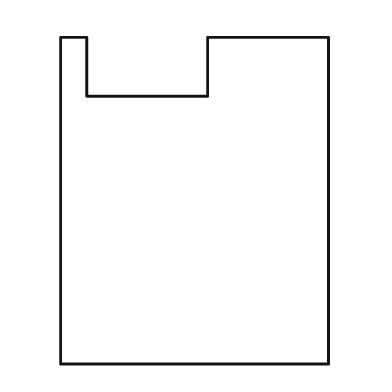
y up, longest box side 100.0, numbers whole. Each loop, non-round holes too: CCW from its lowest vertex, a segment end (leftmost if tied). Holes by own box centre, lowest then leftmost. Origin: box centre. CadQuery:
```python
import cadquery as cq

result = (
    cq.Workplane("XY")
    .moveTo(-41.0, -50.0)
    .lineTo(41.0, -50.0)
    .lineTo(41.0, 50.0)
    .lineTo(4.0, 50.0)
    .lineTo(4.0, 32.0)
    .lineTo(-33.0, 32.0)
    .lineTo(-33.0, 50.0)
    .lineTo(-41.0, 50.0)
    .close()
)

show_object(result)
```